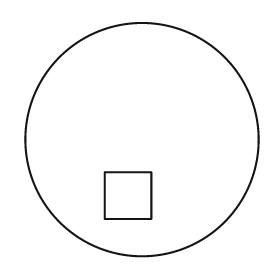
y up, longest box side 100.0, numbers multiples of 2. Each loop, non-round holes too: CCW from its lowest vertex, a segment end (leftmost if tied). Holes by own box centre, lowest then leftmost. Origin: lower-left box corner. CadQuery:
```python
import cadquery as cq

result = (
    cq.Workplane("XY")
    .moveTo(50.0, 50.0)
    .circle(50.0)
    .moveTo(34.0, 16.0)
    .lineTo(54.0, 16.0)
    .lineTo(54.0, 36.0)
    .lineTo(34.0, 36.0)
    .close()
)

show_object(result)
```